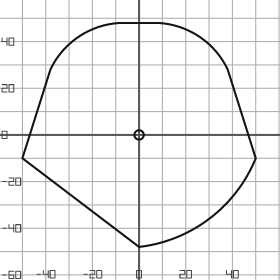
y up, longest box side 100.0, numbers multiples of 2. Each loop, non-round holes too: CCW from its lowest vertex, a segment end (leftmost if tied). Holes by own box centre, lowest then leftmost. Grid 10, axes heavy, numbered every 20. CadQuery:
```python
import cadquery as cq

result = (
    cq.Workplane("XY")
    .moveTo(0.0, -48.0)
    .threePointArc((30.0, -36.0), (50.0, -10.0))
    .lineTo(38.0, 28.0)
    .threePointArc((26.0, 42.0), (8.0, 48.0))
    .lineTo(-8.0, 48.0)
    .threePointArc((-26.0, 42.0), (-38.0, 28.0))
    .lineTo(-50.0, -10.0)
    .close()
    .moveTo(0.0, 0.0)
    .circle(2.0)
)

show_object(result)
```